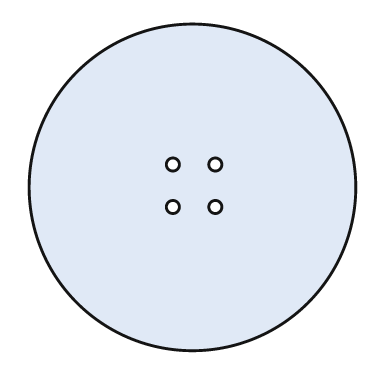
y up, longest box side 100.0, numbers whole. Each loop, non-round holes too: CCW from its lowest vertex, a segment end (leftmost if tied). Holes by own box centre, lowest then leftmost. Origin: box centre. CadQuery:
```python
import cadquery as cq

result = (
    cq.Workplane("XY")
    .moveTo(0.0, 0.0)
    .circle(50.0)
    .moveTo(-6.0, -6.0)
    .circle(2.0)
    .moveTo(7.0, -6.0)
    .circle(2.0)
    .moveTo(-6.0, 7.0)
    .circle(2.0)
    .moveTo(7.0, 7.0)
    .circle(2.0)
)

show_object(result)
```